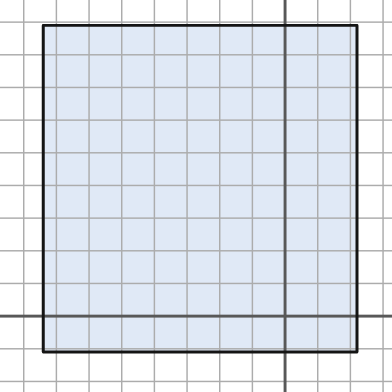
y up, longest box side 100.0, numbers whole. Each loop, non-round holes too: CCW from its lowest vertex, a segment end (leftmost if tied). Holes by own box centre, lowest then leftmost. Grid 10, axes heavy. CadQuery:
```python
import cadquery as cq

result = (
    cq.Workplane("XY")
    .moveTo(-74.0, -11.0)
    .lineTo(22.0, -11.0)
    .lineTo(22.0, 89.0)
    .lineTo(-74.0, 89.0)
    .close()
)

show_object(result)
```